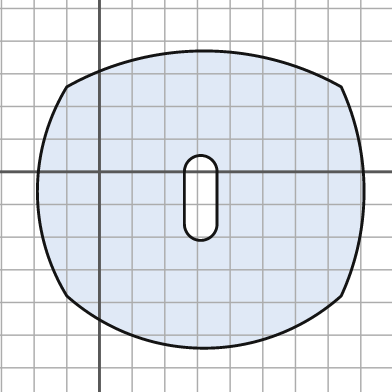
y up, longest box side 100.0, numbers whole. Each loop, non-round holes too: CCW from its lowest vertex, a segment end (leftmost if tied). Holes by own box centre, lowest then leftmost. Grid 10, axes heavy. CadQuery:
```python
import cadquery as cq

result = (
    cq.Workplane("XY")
    .moveTo(-10.0, -38.0)
    .threePointArc((32.0, -54.0), (74.0, -38.0))
    .threePointArc((81.0, -6.0), (74.0, 26.0))
    .threePointArc((32.0, 37.0), (-10.0, 26.0))
    .threePointArc((-19.0, -6.0), (-10.0, -38.0))
    .close()
    .moveTo(26.0, -16.0)
    .threePointArc((31.0, -21.0), (36.0, -16.0))
    .lineTo(36.0, 0.0)
    .threePointArc((31.0, 5.0), (26.0, 0.0))
    .close()
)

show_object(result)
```